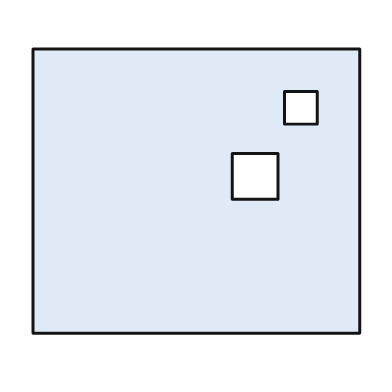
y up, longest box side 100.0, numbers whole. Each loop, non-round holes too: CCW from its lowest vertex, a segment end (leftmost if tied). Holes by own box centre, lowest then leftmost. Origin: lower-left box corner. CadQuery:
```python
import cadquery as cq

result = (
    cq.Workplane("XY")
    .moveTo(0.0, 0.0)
    .lineTo(100.0, 0.0)
    .lineTo(100.0, 87.0)
    .lineTo(0.0, 87.0)
    .close()
    .moveTo(61.0, 41.0)
    .lineTo(75.0, 41.0)
    .lineTo(75.0, 55.0)
    .lineTo(61.0, 55.0)
    .close()
    .moveTo(77.0, 64.0)
    .lineTo(87.0, 64.0)
    .lineTo(87.0, 74.0)
    .lineTo(77.0, 74.0)
    .close()
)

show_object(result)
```